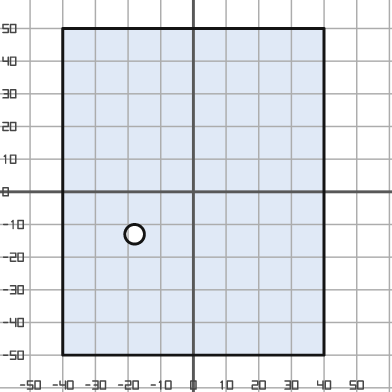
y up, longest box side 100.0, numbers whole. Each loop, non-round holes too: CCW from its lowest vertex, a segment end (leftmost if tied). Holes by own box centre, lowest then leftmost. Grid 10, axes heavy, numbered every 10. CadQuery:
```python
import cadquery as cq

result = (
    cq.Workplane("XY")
    .moveTo(-40.0, -50.0)
    .lineTo(40.0, -50.0)
    .lineTo(40.0, 50.0)
    .lineTo(-40.0, 50.0)
    .close()
    .moveTo(-18.0, -13.0)
    .circle(3.0)
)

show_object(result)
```